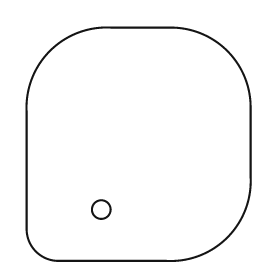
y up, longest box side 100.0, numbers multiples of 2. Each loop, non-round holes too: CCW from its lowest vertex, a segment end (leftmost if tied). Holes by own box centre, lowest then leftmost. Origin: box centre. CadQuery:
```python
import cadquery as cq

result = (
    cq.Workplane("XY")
    .moveTo(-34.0, -50.0)
    .lineTo(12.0, -50.0)
    .threePointArc((38.0, -40.0), (48.0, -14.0))
    .lineTo(48.0, 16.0)
    .threePointArc((38.0, 40.0), (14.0, 50.0))
    .lineTo(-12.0, 50.0)
    .threePointArc((-38.0, 40.0), (-48.0, 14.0))
    .lineTo(-48.0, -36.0)
    .threePointArc((-44.0, -46.0), (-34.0, -50.0))
    .close()
    .moveTo(-16.0, -28.0)
    .circle(4.0)
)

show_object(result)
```